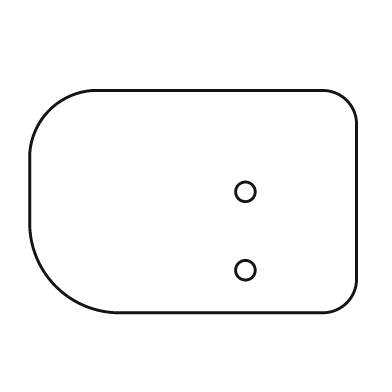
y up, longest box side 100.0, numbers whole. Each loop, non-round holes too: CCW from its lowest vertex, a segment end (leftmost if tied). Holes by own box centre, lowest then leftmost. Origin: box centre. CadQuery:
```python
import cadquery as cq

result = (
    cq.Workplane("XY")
    .moveTo(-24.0, -34.0)
    .lineTo(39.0, -34.0)
    .threePointArc((47.0, -31.0), (50.0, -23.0))
    .lineTo(50.0, 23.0)
    .threePointArc((47.0, 31.0), (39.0, 34.0))
    .lineTo(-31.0, 34.0)
    .threePointArc((-44.0, 28.0), (-50.0, 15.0))
    .lineTo(-50.0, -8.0)
    .threePointArc((-42.0, -26.0), (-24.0, -34.0))
    .close()
    .moveTo(16.0, -21.0)
    .circle(3.0)
    .moveTo(16.0, 3.0)
    .circle(3.0)
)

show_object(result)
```